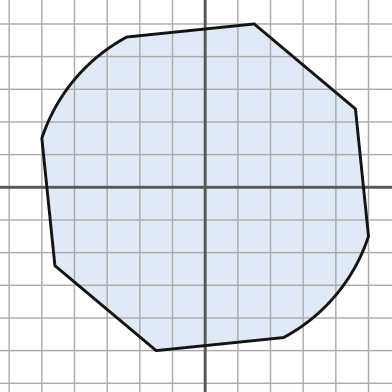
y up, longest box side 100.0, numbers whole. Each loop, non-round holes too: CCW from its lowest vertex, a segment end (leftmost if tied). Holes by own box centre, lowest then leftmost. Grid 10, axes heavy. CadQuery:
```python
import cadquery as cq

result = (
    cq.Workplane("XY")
    .moveTo(-15.0, -50.0)
    .lineTo(24.0, -46.0)
    .threePointArc((40.0, -33.0), (50.0, -15.0))
    .lineTo(46.0, 24.0)
    .lineTo(15.0, 50.0)
    .lineTo(-24.0, 46.0)
    .threePointArc((-40.0, 33.0), (-50.0, 15.0))
    .lineTo(-46.0, -24.0)
    .close()
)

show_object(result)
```